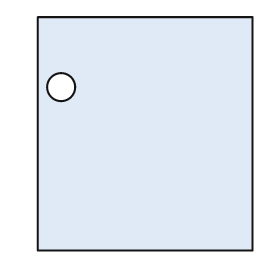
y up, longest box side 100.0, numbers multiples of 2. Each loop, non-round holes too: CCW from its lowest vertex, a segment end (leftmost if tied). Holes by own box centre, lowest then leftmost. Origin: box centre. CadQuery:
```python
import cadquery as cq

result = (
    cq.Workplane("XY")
    .moveTo(-46.0, -50.0)
    .lineTo(46.0, -50.0)
    .lineTo(46.0, 50.0)
    .lineTo(-46.0, 50.0)
    .close()
    .moveTo(-36.0, 20.0)
    .circle(6.0)
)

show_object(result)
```